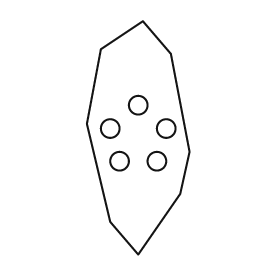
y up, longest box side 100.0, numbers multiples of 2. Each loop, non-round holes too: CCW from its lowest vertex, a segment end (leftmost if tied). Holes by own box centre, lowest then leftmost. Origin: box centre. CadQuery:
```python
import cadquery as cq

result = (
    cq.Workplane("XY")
    .moveTo(0.0, -50.0)
    .lineTo(18.0, -24.0)
    .lineTo(22.0, -6.0)
    .lineTo(14.0, 36.0)
    .lineTo(2.0, 50.0)
    .lineTo(-16.0, 38.0)
    .lineTo(-22.0, 6.0)
    .lineTo(-12.0, -36.0)
    .close()
    .moveTo(-8.0, -10.0)
    .circle(4.0)
    .moveTo(8.0, -10.0)
    .circle(4.0)
    .moveTo(-12.0, 4.0)
    .circle(4.0)
    .moveTo(12.0, 4.0)
    .circle(4.0)
    .moveTo(0.0, 14.0)
    .circle(4.0)
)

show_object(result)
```